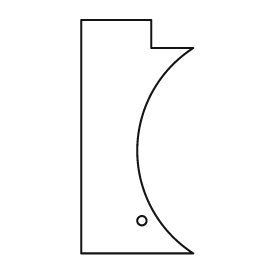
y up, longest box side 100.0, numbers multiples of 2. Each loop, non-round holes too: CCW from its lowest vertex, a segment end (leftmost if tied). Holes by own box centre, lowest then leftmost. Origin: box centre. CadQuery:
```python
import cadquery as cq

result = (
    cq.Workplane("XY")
    .moveTo(-24.0, -50.0)
    .lineTo(24.0, -50.0)
    .threePointArc((0.0, -6.0), (24.0, 38.0))
    .lineTo(6.0, 38.0)
    .lineTo(6.0, 50.0)
    .lineTo(-24.0, 50.0)
    .close()
    .moveTo(2.0, -36.0)
    .circle(2.0)
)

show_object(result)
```